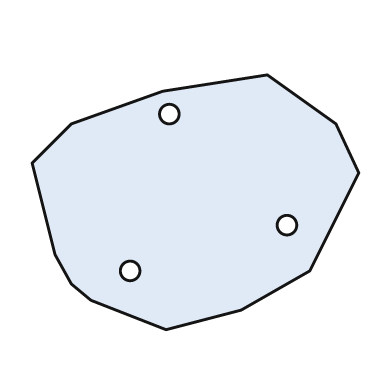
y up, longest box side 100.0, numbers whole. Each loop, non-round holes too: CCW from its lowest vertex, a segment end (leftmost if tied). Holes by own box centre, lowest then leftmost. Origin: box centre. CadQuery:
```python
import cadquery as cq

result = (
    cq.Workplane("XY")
    .moveTo(-9.0, -39.0)
    .lineTo(14.0, -33.0)
    .lineTo(35.0, -21.0)
    .lineTo(50.0, 9.0)
    .lineTo(43.0, 24.0)
    .lineTo(22.0, 39.0)
    .lineTo(-10.0, 34.0)
    .lineTo(-38.0, 24.0)
    .lineTo(-50.0, 12.0)
    .lineTo(-43.0, -16.0)
    .lineTo(-38.0, -25.0)
    .lineTo(-32.0, -30.0)
    .close()
    .moveTo(-20.0, -21.0)
    .circle(3.0)
    .moveTo(28.0, -7.0)
    .circle(3.0)
    .moveTo(-8.0, 27.0)
    .circle(3.0)
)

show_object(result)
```